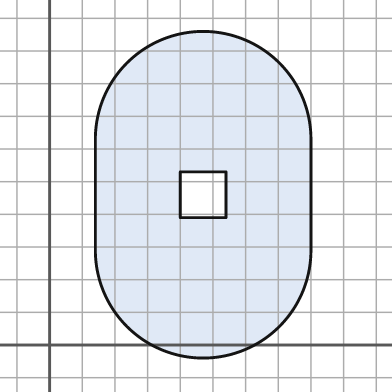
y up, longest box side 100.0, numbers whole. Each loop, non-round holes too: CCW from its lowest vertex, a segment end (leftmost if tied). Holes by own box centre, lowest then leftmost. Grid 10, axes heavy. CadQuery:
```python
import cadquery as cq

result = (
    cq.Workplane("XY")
    .moveTo(14.0, 29.0)
    .threePointArc((47.0, -4.0), (80.0, 29.0))
    .lineTo(80.0, 63.0)
    .threePointArc((47.0, 96.0), (14.0, 63.0))
    .close()
    .moveTo(40.0, 39.0)
    .lineTo(54.0, 39.0)
    .lineTo(54.0, 53.0)
    .lineTo(40.0, 53.0)
    .close()
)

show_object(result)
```